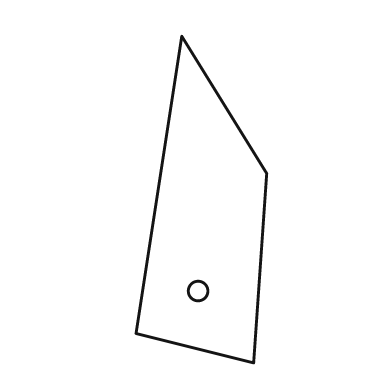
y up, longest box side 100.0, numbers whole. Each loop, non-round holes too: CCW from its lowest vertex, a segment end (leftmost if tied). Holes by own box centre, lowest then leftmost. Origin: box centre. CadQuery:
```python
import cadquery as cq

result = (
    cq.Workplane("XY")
    .moveTo(16.0, -50.0)
    .lineTo(20.0, 8.0)
    .lineTo(-6.0, 50.0)
    .lineTo(-20.0, -41.0)
    .close()
    .moveTo(-1.0, -28.0)
    .circle(3.0)
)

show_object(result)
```